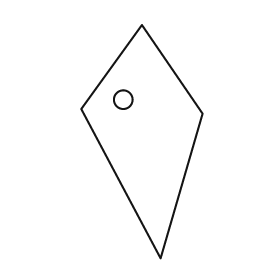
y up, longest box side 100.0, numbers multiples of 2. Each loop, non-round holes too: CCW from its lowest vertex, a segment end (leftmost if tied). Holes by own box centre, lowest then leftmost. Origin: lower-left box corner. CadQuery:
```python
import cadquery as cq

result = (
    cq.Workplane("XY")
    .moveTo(34.0, 0.0)
    .lineTo(52.0, 62.0)
    .lineTo(26.0, 100.0)
    .lineTo(0.0, 64.0)
    .close()
    .moveTo(18.0, 68.0)
    .circle(4.0)
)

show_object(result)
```